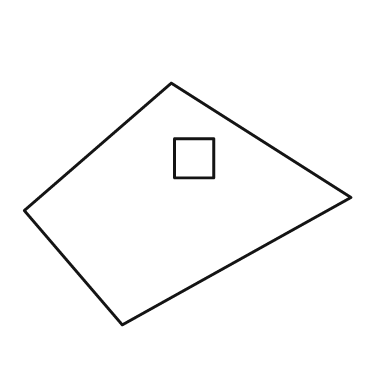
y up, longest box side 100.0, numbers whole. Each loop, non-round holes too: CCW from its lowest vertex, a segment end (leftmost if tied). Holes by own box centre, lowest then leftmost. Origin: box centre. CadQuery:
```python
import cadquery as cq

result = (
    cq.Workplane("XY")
    .moveTo(-20.0, -37.0)
    .lineTo(50.0, 2.0)
    .lineTo(-5.0, 37.0)
    .lineTo(-50.0, -2.0)
    .close()
    .moveTo(-4.0, 8.0)
    .lineTo(8.0, 8.0)
    .lineTo(8.0, 20.0)
    .lineTo(-4.0, 20.0)
    .close()
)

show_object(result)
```